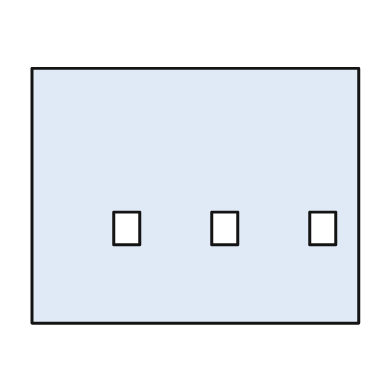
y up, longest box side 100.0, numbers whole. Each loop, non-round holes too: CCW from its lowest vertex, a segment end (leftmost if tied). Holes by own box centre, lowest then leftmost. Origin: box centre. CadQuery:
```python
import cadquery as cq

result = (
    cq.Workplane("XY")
    .moveTo(-50.0, -39.0)
    .lineTo(50.0, -39.0)
    .lineTo(50.0, 39.0)
    .lineTo(-50.0, 39.0)
    .close()
    .moveTo(-25.0, -15.0)
    .lineTo(-17.0, -15.0)
    .lineTo(-17.0, -5.0)
    .lineTo(-25.0, -5.0)
    .close()
    .moveTo(5.0, -15.0)
    .lineTo(13.0, -15.0)
    .lineTo(13.0, -5.0)
    .lineTo(5.0, -5.0)
    .close()
    .moveTo(35.0, -15.0)
    .lineTo(43.0, -15.0)
    .lineTo(43.0, -5.0)
    .lineTo(35.0, -5.0)
    .close()
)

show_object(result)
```